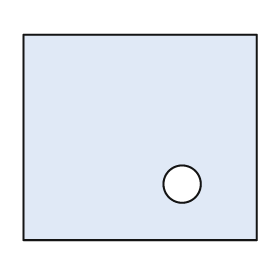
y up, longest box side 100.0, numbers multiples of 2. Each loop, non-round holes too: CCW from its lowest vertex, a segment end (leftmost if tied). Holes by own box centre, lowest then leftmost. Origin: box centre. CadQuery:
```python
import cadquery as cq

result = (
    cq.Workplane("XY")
    .moveTo(-50.0, -44.0)
    .lineTo(50.0, -44.0)
    .lineTo(50.0, 44.0)
    .lineTo(-50.0, 44.0)
    .close()
    .moveTo(18.0, -20.0)
    .circle(8.0)
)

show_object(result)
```